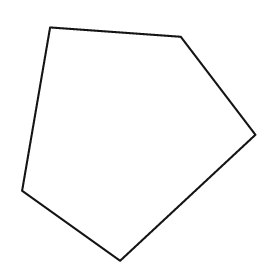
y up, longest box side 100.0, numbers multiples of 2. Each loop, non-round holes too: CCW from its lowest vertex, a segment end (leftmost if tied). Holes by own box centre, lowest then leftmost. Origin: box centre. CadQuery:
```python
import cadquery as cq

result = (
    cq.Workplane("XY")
    .moveTo(-8.0, -50.0)
    .lineTo(50.0, 4.0)
    .lineTo(18.0, 46.0)
    .lineTo(-38.0, 50.0)
    .lineTo(-50.0, -20.0)
    .close()
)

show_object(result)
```